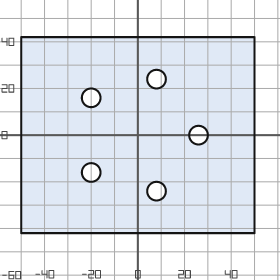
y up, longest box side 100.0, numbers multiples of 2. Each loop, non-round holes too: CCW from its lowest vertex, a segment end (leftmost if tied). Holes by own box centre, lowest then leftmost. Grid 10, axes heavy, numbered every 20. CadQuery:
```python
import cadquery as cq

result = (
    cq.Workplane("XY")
    .moveTo(-50.0, -42.0)
    .lineTo(50.0, -42.0)
    .lineTo(50.0, 42.0)
    .lineTo(-50.0, 42.0)
    .close()
    .moveTo(8.0, -24.0)
    .circle(4.0)
    .moveTo(-20.0, -16.0)
    .circle(4.0)
    .moveTo(26.0, 0.0)
    .circle(4.0)
    .moveTo(-20.0, 16.0)
    .circle(4.0)
    .moveTo(8.0, 24.0)
    .circle(4.0)
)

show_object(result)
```